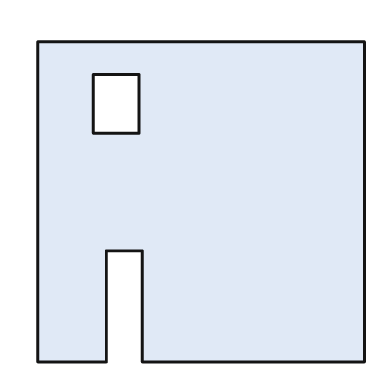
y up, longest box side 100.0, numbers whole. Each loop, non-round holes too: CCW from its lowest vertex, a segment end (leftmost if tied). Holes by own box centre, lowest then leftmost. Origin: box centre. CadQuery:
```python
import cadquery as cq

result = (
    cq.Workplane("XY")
    .moveTo(-50.0, -49.0)
    .lineTo(-29.0, -49.0)
    .lineTo(-29.0, -15.0)
    .lineTo(-18.0, -15.0)
    .lineTo(-18.0, -49.0)
    .lineTo(50.0, -49.0)
    .lineTo(50.0, 49.0)
    .lineTo(-50.0, 49.0)
    .close()
    .moveTo(-33.0, 21.0)
    .lineTo(-19.0, 21.0)
    .lineTo(-19.0, 39.0)
    .lineTo(-33.0, 39.0)
    .close()
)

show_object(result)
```